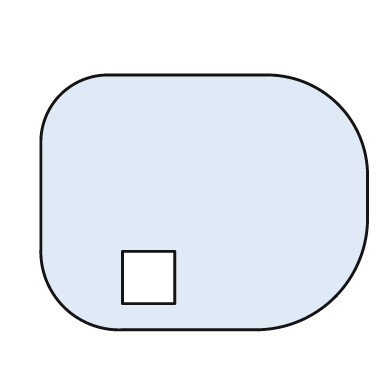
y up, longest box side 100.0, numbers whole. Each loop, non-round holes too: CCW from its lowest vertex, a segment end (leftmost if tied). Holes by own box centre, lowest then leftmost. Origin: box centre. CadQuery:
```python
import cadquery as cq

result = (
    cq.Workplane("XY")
    .moveTo(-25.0, -39.0)
    .lineTo(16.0, -39.0)
    .threePointArc((40.0, -29.0), (50.0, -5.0))
    .lineTo(50.0, 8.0)
    .threePointArc((41.0, 30.0), (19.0, 39.0))
    .lineTo(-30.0, 39.0)
    .threePointArc((-44.0, 33.0), (-50.0, 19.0))
    .lineTo(-50.0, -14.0)
    .threePointArc((-43.0, -32.0), (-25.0, -39.0))
    .close()
    .moveTo(-25.0, -31.0)
    .lineTo(-9.0, -31.0)
    .lineTo(-9.0, -15.0)
    .lineTo(-25.0, -15.0)
    .close()
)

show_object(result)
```